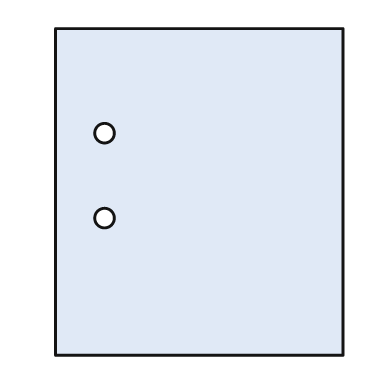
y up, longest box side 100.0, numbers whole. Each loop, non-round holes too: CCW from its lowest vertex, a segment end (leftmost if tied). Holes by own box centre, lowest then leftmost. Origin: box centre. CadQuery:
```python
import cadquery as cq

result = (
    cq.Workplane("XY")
    .moveTo(-44.0, -50.0)
    .lineTo(44.0, -50.0)
    .lineTo(44.0, 50.0)
    .lineTo(-44.0, 50.0)
    .close()
    .moveTo(-29.0, -8.0)
    .circle(3.0)
    .moveTo(-29.0, 18.0)
    .circle(3.0)
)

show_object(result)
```